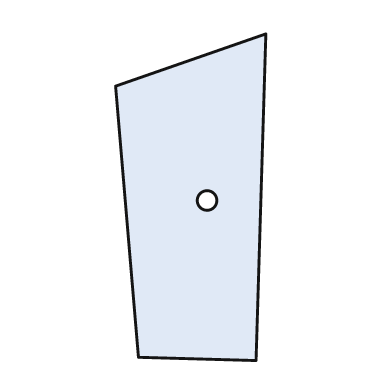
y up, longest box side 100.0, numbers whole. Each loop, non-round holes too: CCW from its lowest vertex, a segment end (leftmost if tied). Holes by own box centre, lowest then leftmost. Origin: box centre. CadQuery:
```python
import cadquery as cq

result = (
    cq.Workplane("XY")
    .moveTo(20.0, -50.0)
    .lineTo(23.0, 50.0)
    .lineTo(-23.0, 34.0)
    .lineTo(-16.0, -49.0)
    .close()
    .moveTo(5.0, -1.0)
    .circle(3.0)
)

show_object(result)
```